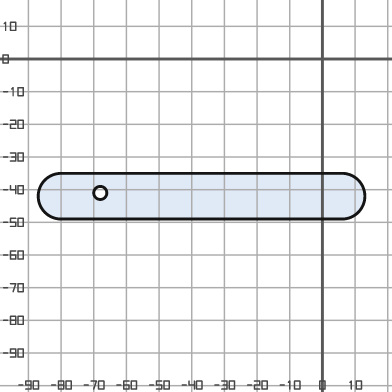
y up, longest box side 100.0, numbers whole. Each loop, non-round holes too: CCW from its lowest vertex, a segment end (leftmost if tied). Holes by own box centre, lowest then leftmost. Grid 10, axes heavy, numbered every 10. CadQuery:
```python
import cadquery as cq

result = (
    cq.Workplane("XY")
    .moveTo(-80.0, -49.0)
    .lineTo(6.0, -49.0)
    .threePointArc((13.0, -42.0), (6.0, -35.0))
    .lineTo(-80.0, -35.0)
    .threePointArc((-87.0, -42.0), (-80.0, -49.0))
    .close()
    .moveTo(-68.0, -41.0)
    .circle(2.0)
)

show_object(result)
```